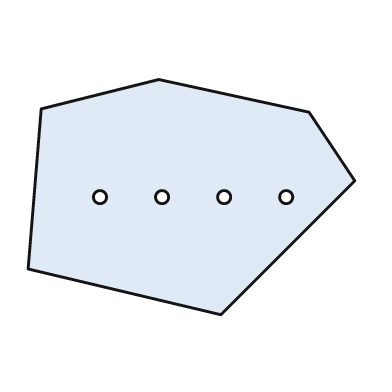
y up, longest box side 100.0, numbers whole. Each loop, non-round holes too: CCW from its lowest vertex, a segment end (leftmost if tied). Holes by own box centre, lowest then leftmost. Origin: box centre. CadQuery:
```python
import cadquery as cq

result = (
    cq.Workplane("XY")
    .moveTo(9.0, -36.0)
    .lineTo(50.0, 5.0)
    .lineTo(36.0, 26.0)
    .lineTo(-10.0, 36.0)
    .lineTo(-46.0, 27.0)
    .lineTo(-50.0, -22.0)
    .close()
    .moveTo(-28.0, 0.0)
    .circle(2.0)
    .moveTo(-9.0, 0.0)
    .circle(2.0)
    .moveTo(10.0, 0.0)
    .circle(2.0)
    .moveTo(29.0, 0.0)
    .circle(2.0)
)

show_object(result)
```